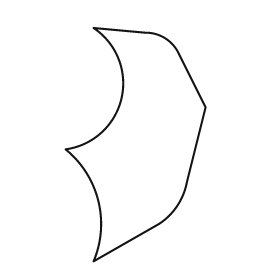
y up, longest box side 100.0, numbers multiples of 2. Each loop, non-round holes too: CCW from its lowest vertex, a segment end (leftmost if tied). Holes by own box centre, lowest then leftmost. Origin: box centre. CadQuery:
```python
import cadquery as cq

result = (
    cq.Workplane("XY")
    .moveTo(-18.0, -50.0)
    .lineTo(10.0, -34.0)
    .threePointArc((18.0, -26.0), (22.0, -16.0))
    .lineTo(30.0, 16.0)
    .lineTo(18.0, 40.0)
    .threePointArc((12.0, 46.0), (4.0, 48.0))
    .lineTo(-18.0, 50.0)
    .threePointArc((-6.0, 20.0), (-30.0, -2.0))
    .threePointArc((-16.0, -24.0), (-18.0, -50.0))
    .close()
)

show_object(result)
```